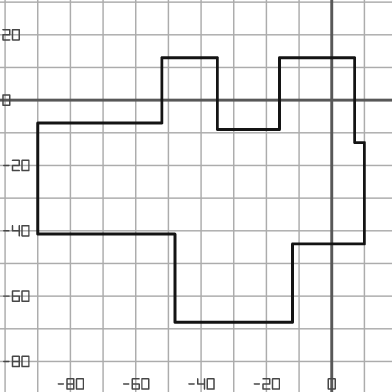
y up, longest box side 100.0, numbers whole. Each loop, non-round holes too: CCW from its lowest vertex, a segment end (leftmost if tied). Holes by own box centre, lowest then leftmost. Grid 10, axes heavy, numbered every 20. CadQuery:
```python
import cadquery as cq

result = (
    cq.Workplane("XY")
    .moveTo(-48.0, -68.0)
    .lineTo(-12.0, -68.0)
    .lineTo(-12.0, -44.0)
    .lineTo(10.0, -44.0)
    .lineTo(10.0, -13.0)
    .lineTo(7.0, -13.0)
    .lineTo(7.0, 13.0)
    .lineTo(-16.0, 13.0)
    .lineTo(-16.0, -9.0)
    .lineTo(-35.0, -9.0)
    .lineTo(-35.0, 13.0)
    .lineTo(-52.0, 13.0)
    .lineTo(-52.0, -7.0)
    .lineTo(-90.0, -7.0)
    .lineTo(-90.0, -41.0)
    .lineTo(-48.0, -41.0)
    .close()
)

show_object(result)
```